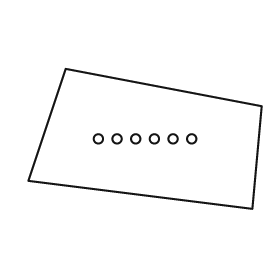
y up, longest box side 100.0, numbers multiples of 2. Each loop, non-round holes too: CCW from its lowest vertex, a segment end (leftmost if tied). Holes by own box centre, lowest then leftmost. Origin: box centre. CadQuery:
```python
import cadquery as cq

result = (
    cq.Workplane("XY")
    .moveTo(46.0, -30.0)
    .lineTo(50.0, 14.0)
    .lineTo(-34.0, 30.0)
    .lineTo(-50.0, -18.0)
    .close()
    .moveTo(-20.0, 0.0)
    .circle(2.0)
    .moveTo(-12.0, 0.0)
    .circle(2.0)
    .moveTo(-4.0, 0.0)
    .circle(2.0)
    .moveTo(4.0, 0.0)
    .circle(2.0)
    .moveTo(12.0, 0.0)
    .circle(2.0)
    .moveTo(20.0, 0.0)
    .circle(2.0)
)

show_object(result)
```